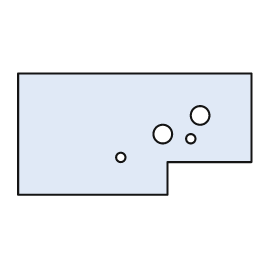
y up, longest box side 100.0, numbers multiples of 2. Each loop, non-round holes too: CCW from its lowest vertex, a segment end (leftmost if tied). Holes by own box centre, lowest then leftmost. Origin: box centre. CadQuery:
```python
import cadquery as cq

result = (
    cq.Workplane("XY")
    .moveTo(-50.0, -26.0)
    .lineTo(14.0, -26.0)
    .lineTo(14.0, -12.0)
    .lineTo(50.0, -12.0)
    .lineTo(50.0, 26.0)
    .lineTo(-50.0, 26.0)
    .close()
    .moveTo(-6.0, -10.0)
    .circle(2.0)
    .moveTo(24.0, -2.0)
    .circle(2.0)
    .moveTo(12.0, 0.0)
    .circle(4.0)
    .moveTo(28.0, 8.0)
    .circle(4.0)
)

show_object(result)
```